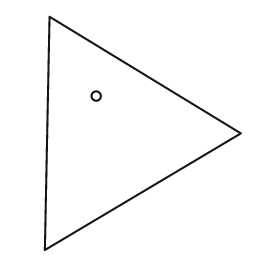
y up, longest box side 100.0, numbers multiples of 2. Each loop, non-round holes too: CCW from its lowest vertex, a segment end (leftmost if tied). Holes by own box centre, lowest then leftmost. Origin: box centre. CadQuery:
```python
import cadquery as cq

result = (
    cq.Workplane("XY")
    .moveTo(-42.0, -50.0)
    .lineTo(42.0, 0.0)
    .lineTo(-40.0, 50.0)
    .close()
    .moveTo(-20.0, 16.0)
    .circle(2.0)
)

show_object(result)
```